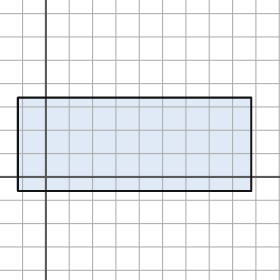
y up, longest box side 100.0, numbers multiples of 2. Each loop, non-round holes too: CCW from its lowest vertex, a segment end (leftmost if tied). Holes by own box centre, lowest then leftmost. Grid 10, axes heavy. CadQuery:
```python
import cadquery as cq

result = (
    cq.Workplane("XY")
    .moveTo(-12.0, -6.0)
    .lineTo(88.0, -6.0)
    .lineTo(88.0, 34.0)
    .lineTo(-12.0, 34.0)
    .close()
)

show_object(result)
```